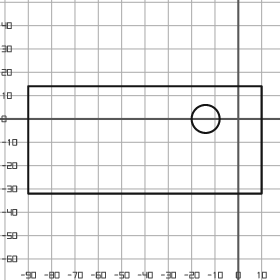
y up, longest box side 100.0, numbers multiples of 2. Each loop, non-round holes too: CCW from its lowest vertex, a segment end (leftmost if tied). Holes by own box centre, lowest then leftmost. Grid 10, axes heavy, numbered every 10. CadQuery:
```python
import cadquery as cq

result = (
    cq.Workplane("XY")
    .moveTo(-90.0, -32.0)
    .lineTo(10.0, -32.0)
    .lineTo(10.0, 14.0)
    .lineTo(-90.0, 14.0)
    .close()
    .moveTo(-14.0, 0.0)
    .circle(6.0)
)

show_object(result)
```